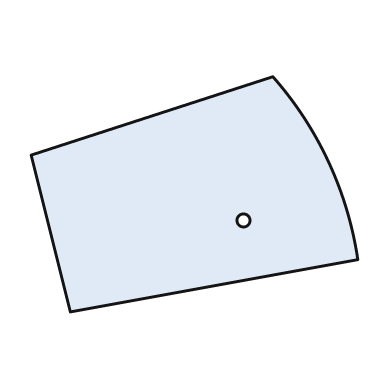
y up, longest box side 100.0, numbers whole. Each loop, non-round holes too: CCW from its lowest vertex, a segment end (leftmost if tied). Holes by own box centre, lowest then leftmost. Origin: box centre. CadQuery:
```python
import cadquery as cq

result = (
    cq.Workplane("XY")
    .moveTo(-38.0, -36.0)
    .lineTo(50.0, -20.0)
    .threePointArc((41.0, 10.0), (24.0, 36.0))
    .lineTo(-50.0, 12.0)
    .close()
    .moveTo(15.0, -8.0)
    .circle(2.0)
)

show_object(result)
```